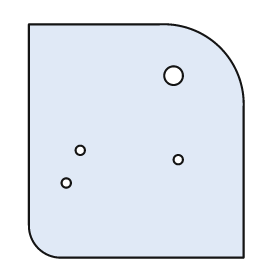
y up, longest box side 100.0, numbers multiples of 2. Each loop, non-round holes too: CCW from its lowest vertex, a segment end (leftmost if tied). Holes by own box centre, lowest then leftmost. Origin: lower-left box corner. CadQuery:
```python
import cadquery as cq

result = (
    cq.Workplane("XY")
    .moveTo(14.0, 0.0)
    .lineTo(92.0, 0.0)
    .lineTo(92.0, 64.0)
    .threePointArc((82.0, 90.0), (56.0, 100.0))
    .lineTo(0.0, 100.0)
    .lineTo(0.0, 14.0)
    .threePointArc((4.0, 4.0), (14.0, 0.0))
    .close()
    .moveTo(16.0, 32.0)
    .circle(2.0)
    .moveTo(64.0, 42.0)
    .circle(2.0)
    .moveTo(22.0, 46.0)
    .circle(2.0)
    .moveTo(62.0, 78.0)
    .circle(4.0)
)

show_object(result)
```